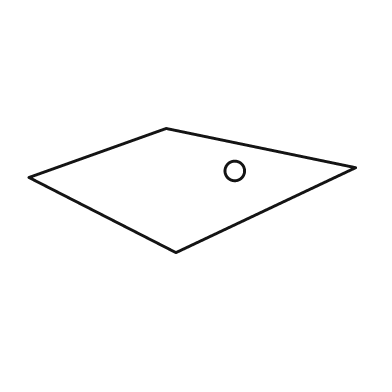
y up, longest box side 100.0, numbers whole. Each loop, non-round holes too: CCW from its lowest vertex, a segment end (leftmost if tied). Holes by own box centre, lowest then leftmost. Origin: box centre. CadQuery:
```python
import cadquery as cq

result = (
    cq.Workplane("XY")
    .moveTo(-5.0, -19.0)
    .lineTo(50.0, 7.0)
    .lineTo(-8.0, 19.0)
    .lineTo(-50.0, 4.0)
    .close()
    .moveTo(13.0, 6.0)
    .circle(3.0)
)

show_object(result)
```